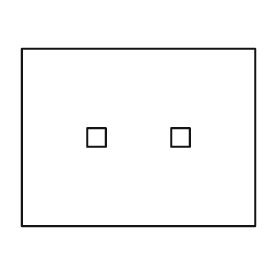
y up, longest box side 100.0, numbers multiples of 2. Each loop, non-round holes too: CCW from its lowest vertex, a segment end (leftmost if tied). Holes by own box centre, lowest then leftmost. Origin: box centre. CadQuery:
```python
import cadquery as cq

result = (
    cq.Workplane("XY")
    .moveTo(-50.0, -38.0)
    .lineTo(50.0, -38.0)
    .lineTo(50.0, 38.0)
    .lineTo(-50.0, 38.0)
    .close()
    .moveTo(-22.0, -4.0)
    .lineTo(-14.0, -4.0)
    .lineTo(-14.0, 4.0)
    .lineTo(-22.0, 4.0)
    .close()
    .moveTo(14.0, -4.0)
    .lineTo(22.0, -4.0)
    .lineTo(22.0, 4.0)
    .lineTo(14.0, 4.0)
    .close()
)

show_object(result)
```